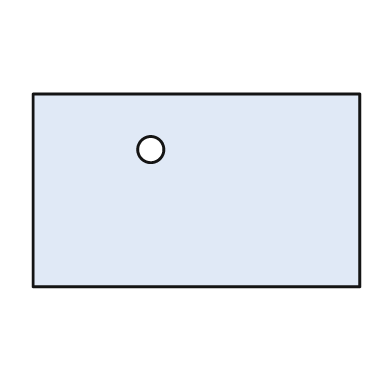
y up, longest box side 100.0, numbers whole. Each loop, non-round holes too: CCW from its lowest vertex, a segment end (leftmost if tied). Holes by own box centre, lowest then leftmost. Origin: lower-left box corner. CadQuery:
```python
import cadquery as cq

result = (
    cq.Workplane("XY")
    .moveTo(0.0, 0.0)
    .lineTo(100.0, 0.0)
    .lineTo(100.0, 59.0)
    .lineTo(0.0, 59.0)
    .close()
    .moveTo(36.0, 42.0)
    .circle(4.0)
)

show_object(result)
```